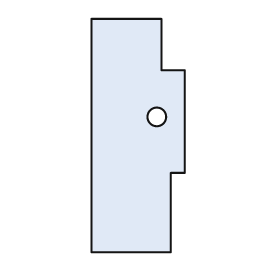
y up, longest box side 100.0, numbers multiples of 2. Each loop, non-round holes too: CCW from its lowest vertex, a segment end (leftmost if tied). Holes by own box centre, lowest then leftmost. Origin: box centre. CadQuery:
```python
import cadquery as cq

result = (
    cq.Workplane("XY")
    .moveTo(-20.0, -50.0)
    .lineTo(14.0, -50.0)
    .lineTo(14.0, -16.0)
    .lineTo(20.0, -16.0)
    .lineTo(20.0, 28.0)
    .lineTo(10.0, 28.0)
    .lineTo(10.0, 50.0)
    .lineTo(-20.0, 50.0)
    .close()
    .moveTo(8.0, 8.0)
    .circle(4.0)
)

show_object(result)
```